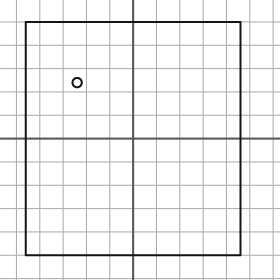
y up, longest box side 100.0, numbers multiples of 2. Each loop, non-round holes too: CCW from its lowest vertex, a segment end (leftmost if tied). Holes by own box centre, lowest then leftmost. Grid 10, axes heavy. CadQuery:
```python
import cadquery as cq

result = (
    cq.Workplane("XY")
    .moveTo(-46.0, -50.0)
    .lineTo(46.0, -50.0)
    .lineTo(46.0, 50.0)
    .lineTo(-46.0, 50.0)
    .close()
    .moveTo(-24.0, 24.0)
    .circle(2.0)
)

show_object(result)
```